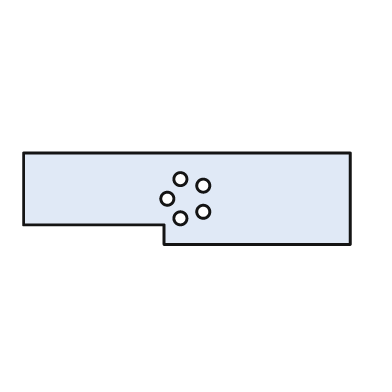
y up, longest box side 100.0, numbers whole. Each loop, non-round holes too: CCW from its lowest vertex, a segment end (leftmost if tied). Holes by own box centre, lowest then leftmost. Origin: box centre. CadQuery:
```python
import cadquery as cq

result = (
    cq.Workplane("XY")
    .moveTo(-7.0, -14.0)
    .lineTo(50.0, -14.0)
    .lineTo(50.0, 14.0)
    .lineTo(-50.0, 14.0)
    .lineTo(-50.0, -8.0)
    .lineTo(-7.0, -8.0)
    .close()
    .moveTo(-2.0, -6.0)
    .circle(2.0)
    .moveTo(5.0, -4.0)
    .circle(2.0)
    .moveTo(-6.0, 0.0)
    .circle(2.0)
    .moveTo(5.0, 4.0)
    .circle(2.0)
    .moveTo(-2.0, 6.0)
    .circle(2.0)
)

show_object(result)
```